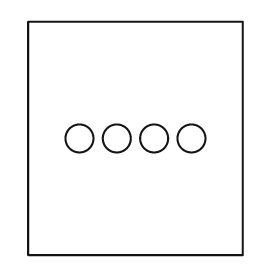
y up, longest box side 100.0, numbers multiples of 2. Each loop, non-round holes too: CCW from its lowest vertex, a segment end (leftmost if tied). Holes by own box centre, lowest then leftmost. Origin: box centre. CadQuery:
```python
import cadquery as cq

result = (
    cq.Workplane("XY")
    .moveTo(-46.0, -50.0)
    .lineTo(46.0, -50.0)
    .lineTo(46.0, 50.0)
    .lineTo(-46.0, 50.0)
    .close()
    .moveTo(-24.0, 0.0)
    .circle(6.0)
    .moveTo(-8.0, 0.0)
    .circle(6.0)
    .moveTo(8.0, 0.0)
    .circle(6.0)
    .moveTo(24.0, 0.0)
    .circle(6.0)
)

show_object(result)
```